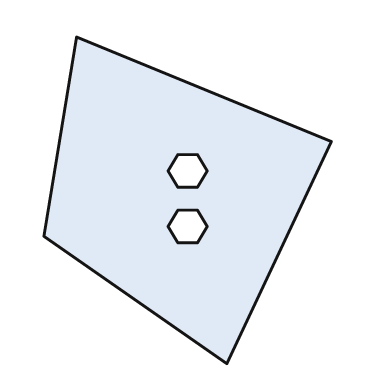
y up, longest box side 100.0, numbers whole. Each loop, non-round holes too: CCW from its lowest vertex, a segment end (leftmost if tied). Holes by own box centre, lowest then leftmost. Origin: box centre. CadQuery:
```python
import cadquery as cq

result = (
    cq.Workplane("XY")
    .moveTo(12.0, -50.0)
    .lineTo(44.0, 18.0)
    .lineTo(-34.0, 50.0)
    .lineTo(-44.0, -11.0)
    .close()
    .moveTo(-3.0, -13.0)
    .lineTo(3.0, -13.0)
    .lineTo(6.0, -8.0)
    .lineTo(3.0, -3.0)
    .lineTo(-3.0, -3.0)
    .lineTo(-6.0, -8.0)
    .close()
    .moveTo(-3.0, 4.0)
    .lineTo(3.0, 4.0)
    .lineTo(6.0, 9.0)
    .lineTo(3.0, 14.0)
    .lineTo(-3.0, 14.0)
    .lineTo(-6.0, 9.0)
    .close()
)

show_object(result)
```